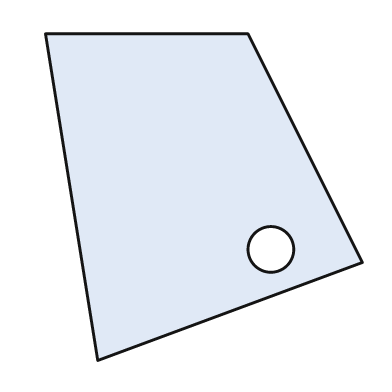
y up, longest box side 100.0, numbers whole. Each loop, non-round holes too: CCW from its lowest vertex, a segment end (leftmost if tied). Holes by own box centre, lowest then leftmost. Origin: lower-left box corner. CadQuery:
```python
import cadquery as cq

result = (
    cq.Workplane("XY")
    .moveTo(16.0, 0.0)
    .lineTo(97.0, 30.0)
    .lineTo(62.0, 100.0)
    .lineTo(0.0, 100.0)
    .close()
    .moveTo(69.0, 34.0)
    .circle(7.0)
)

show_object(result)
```